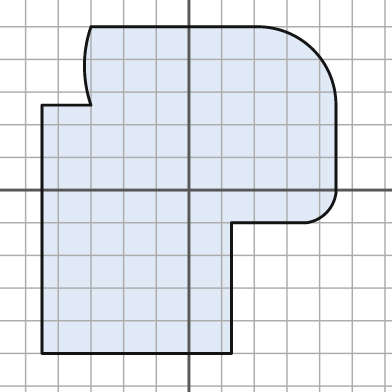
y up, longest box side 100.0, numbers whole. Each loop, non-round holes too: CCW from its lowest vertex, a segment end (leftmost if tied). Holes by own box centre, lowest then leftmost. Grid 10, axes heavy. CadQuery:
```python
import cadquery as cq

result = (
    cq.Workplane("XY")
    .moveTo(-45.0, -50.0)
    .lineTo(13.0, -50.0)
    .lineTo(13.0, -10.0)
    .lineTo(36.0, -10.0)
    .threePointArc((42.0, -7.0), (45.0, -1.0))
    .lineTo(45.0, 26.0)
    .threePointArc((38.0, 43.0), (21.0, 50.0))
    .lineTo(-30.0, 50.0)
    .threePointArc((-32.0, 38.0), (-30.0, 26.0))
    .lineTo(-45.0, 26.0)
    .close()
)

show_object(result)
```